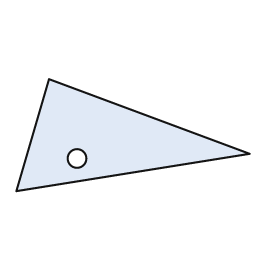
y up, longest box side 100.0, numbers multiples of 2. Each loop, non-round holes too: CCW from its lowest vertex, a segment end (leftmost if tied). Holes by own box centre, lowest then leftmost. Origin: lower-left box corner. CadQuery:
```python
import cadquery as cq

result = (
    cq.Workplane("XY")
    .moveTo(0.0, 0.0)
    .lineTo(100.0, 16.0)
    .lineTo(14.0, 48.0)
    .close()
    .moveTo(26.0, 14.0)
    .circle(4.0)
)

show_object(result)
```